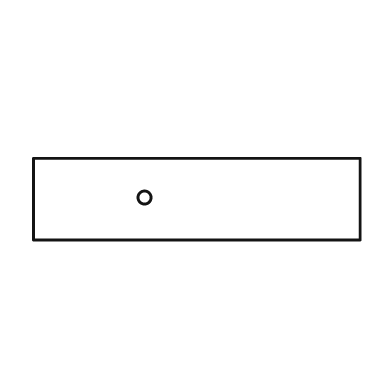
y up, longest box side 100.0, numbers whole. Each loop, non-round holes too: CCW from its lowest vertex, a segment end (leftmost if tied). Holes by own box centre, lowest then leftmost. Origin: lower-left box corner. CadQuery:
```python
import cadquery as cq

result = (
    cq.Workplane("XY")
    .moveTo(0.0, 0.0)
    .lineTo(100.0, 0.0)
    .lineTo(100.0, 25.0)
    .lineTo(0.0, 25.0)
    .close()
    .moveTo(34.0, 13.0)
    .circle(2.0)
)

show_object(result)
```